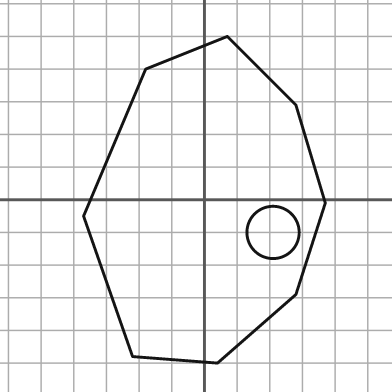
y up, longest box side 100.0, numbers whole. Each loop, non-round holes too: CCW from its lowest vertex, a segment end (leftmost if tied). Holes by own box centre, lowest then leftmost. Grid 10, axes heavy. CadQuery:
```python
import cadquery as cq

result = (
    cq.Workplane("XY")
    .moveTo(4.0, -50.0)
    .lineTo(28.0, -29.0)
    .lineTo(37.0, -1.0)
    .lineTo(28.0, 29.0)
    .lineTo(7.0, 50.0)
    .lineTo(-18.0, 40.0)
    .lineTo(-37.0, -5.0)
    .lineTo(-22.0, -48.0)
    .close()
    .moveTo(21.0, -10.0)
    .circle(8.0)
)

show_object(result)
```